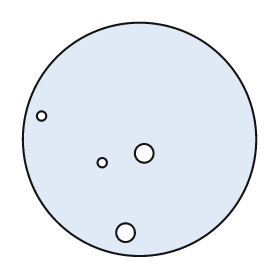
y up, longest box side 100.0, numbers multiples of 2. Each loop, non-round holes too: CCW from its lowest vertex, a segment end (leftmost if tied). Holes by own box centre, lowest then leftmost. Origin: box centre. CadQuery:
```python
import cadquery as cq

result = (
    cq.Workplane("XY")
    .moveTo(0.0, 0.0)
    .circle(50.0)
    .moveTo(-6.0, -40.0)
    .circle(4.0)
    .moveTo(-16.0, -10.0)
    .circle(2.0)
    .moveTo(2.0, -6.0)
    .circle(4.0)
    .moveTo(-42.0, 10.0)
    .circle(2.0)
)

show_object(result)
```